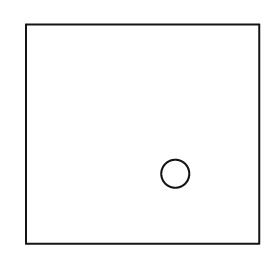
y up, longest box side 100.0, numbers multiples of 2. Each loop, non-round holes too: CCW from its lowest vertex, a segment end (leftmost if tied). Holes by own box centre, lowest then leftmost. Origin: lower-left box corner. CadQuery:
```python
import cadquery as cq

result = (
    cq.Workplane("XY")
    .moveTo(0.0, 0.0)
    .lineTo(100.0, 0.0)
    .lineTo(100.0, 94.0)
    .lineTo(0.0, 94.0)
    .close()
    .moveTo(64.0, 30.0)
    .circle(6.0)
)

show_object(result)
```